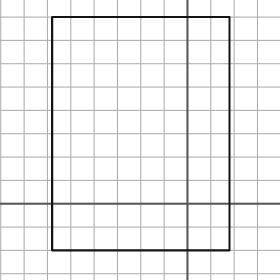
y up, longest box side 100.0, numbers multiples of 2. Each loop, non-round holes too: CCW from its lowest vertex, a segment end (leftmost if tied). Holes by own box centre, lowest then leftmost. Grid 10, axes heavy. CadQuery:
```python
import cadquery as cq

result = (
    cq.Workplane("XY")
    .moveTo(-58.0, -20.0)
    .lineTo(18.0, -20.0)
    .lineTo(18.0, 80.0)
    .lineTo(-58.0, 80.0)
    .close()
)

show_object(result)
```